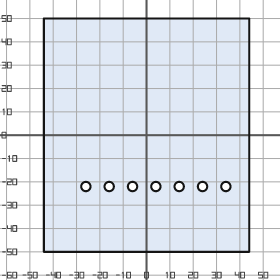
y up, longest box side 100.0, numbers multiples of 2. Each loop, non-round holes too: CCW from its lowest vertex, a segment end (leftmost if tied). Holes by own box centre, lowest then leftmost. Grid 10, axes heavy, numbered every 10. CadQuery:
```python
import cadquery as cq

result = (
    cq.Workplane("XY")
    .moveTo(-44.0, -50.0)
    .lineTo(44.0, -50.0)
    .lineTo(44.0, 50.0)
    .lineTo(-44.0, 50.0)
    .close()
    .moveTo(-26.0, -22.0)
    .circle(2.0)
    .moveTo(-16.0, -22.0)
    .circle(2.0)
    .moveTo(-6.0, -22.0)
    .circle(2.0)
    .moveTo(4.0, -22.0)
    .circle(2.0)
    .moveTo(14.0, -22.0)
    .circle(2.0)
    .moveTo(24.0, -22.0)
    .circle(2.0)
    .moveTo(34.0, -22.0)
    .circle(2.0)
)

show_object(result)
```